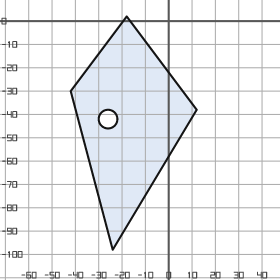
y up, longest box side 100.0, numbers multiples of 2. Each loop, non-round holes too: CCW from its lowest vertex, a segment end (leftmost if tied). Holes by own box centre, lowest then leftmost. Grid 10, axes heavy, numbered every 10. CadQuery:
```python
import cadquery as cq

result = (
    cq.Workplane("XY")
    .moveTo(-24.0, -98.0)
    .lineTo(12.0, -38.0)
    .lineTo(-18.0, 2.0)
    .lineTo(-42.0, -30.0)
    .close()
    .moveTo(-26.0, -42.0)
    .circle(4.0)
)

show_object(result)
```